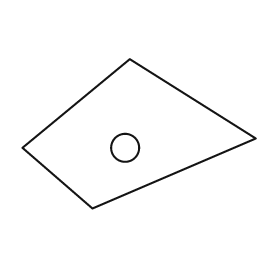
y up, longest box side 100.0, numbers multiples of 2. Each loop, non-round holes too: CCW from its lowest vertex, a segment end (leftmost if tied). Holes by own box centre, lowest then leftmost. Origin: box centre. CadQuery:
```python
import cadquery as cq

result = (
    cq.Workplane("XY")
    .moveTo(-20.0, -32.0)
    .lineTo(50.0, -2.0)
    .lineTo(-4.0, 32.0)
    .lineTo(-50.0, -6.0)
    .close()
    .moveTo(-6.0, -6.0)
    .circle(6.0)
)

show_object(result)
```